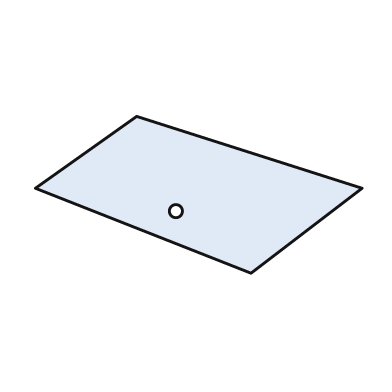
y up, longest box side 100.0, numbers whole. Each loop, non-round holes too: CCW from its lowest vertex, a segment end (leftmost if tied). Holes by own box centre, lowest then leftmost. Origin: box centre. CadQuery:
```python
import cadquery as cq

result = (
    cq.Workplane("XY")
    .moveTo(16.0, -24.0)
    .lineTo(50.0, 2.0)
    .lineTo(-19.0, 24.0)
    .lineTo(-50.0, 2.0)
    .close()
    .moveTo(-7.0, -5.0)
    .circle(2.0)
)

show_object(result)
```